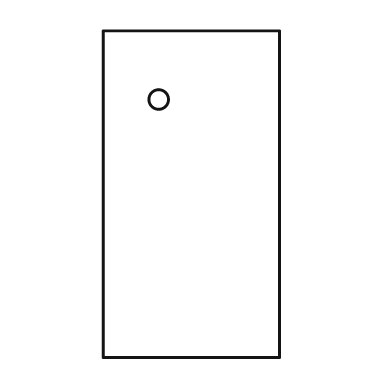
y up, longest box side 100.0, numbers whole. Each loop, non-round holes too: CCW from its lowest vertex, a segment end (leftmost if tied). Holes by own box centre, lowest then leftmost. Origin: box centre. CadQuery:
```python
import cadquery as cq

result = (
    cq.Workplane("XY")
    .moveTo(-27.0, -50.0)
    .lineTo(27.0, -50.0)
    .lineTo(27.0, 50.0)
    .lineTo(-27.0, 50.0)
    .close()
    .moveTo(-10.0, 29.0)
    .circle(3.0)
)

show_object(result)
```